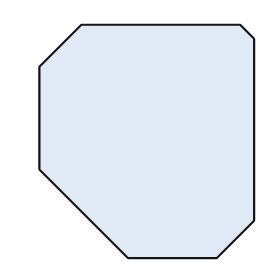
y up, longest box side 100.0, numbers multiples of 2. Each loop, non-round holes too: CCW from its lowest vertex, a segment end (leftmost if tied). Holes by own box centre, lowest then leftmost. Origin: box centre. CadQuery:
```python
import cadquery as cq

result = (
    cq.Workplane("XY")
    .moveTo(-8.0, -50.0)
    .lineTo(30.0, -50.0)
    .lineTo(46.0, -34.0)
    .lineTo(46.0, 44.0)
    .lineTo(40.0, 50.0)
    .lineTo(-28.0, 50.0)
    .lineTo(-46.0, 32.0)
    .lineTo(-46.0, -12.0)
    .close()
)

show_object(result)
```